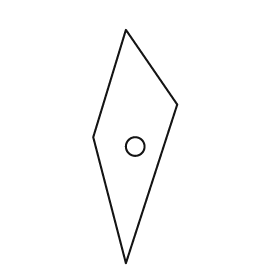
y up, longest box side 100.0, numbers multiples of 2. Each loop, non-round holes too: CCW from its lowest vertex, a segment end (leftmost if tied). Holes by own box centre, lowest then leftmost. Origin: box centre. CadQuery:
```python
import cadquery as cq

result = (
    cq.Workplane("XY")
    .moveTo(-4.0, -50.0)
    .lineTo(18.0, 18.0)
    .lineTo(-4.0, 50.0)
    .lineTo(-18.0, 4.0)
    .close()
    .moveTo(0.0, 0.0)
    .circle(4.0)
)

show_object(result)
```